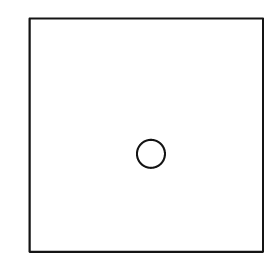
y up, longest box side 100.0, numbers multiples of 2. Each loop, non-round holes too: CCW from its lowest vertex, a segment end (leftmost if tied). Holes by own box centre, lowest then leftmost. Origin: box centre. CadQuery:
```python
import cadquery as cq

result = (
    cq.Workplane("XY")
    .moveTo(-50.0, -50.0)
    .lineTo(50.0, -50.0)
    .lineTo(50.0, 50.0)
    .lineTo(-50.0, 50.0)
    .close()
    .moveTo(2.0, -8.0)
    .circle(6.0)
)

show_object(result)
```